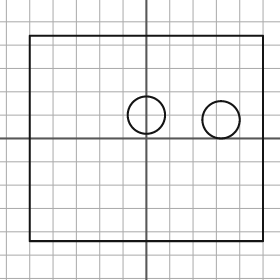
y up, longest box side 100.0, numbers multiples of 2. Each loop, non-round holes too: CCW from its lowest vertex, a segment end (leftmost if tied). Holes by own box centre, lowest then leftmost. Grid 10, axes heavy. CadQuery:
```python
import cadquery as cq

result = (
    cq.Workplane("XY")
    .moveTo(-50.0, -44.0)
    .lineTo(50.0, -44.0)
    .lineTo(50.0, 44.0)
    .lineTo(-50.0, 44.0)
    .close()
    .moveTo(32.0, 8.0)
    .circle(8.0)
    .moveTo(0.0, 10.0)
    .circle(8.0)
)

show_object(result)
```